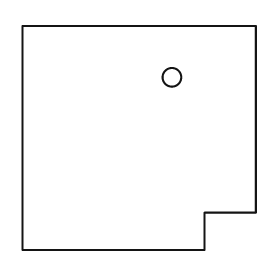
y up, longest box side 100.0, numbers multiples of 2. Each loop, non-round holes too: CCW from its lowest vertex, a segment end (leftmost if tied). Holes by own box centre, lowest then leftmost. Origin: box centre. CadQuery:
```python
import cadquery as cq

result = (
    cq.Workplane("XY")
    .moveTo(-50.0, -48.0)
    .lineTo(28.0, -48.0)
    .lineTo(28.0, -32.0)
    .lineTo(50.0, -32.0)
    .lineTo(50.0, 48.0)
    .lineTo(-50.0, 48.0)
    .close()
    .moveTo(14.0, 26.0)
    .circle(4.0)
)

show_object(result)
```